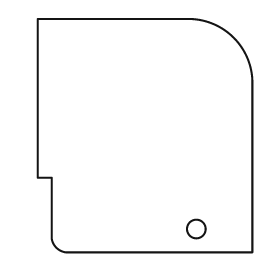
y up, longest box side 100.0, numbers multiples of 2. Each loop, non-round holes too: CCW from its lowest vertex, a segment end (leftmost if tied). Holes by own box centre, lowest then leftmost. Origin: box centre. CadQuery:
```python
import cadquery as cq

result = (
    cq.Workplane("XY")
    .moveTo(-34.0, -50.0)
    .lineTo(46.0, -50.0)
    .lineTo(46.0, 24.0)
    .threePointArc((38.0, 42.0), (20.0, 50.0))
    .lineTo(-46.0, 50.0)
    .lineTo(-46.0, -18.0)
    .lineTo(-40.0, -18.0)
    .lineTo(-40.0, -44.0)
    .threePointArc((-38.0, -48.0), (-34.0, -50.0))
    .close()
    .moveTo(22.0, -40.0)
    .circle(4.0)
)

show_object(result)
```